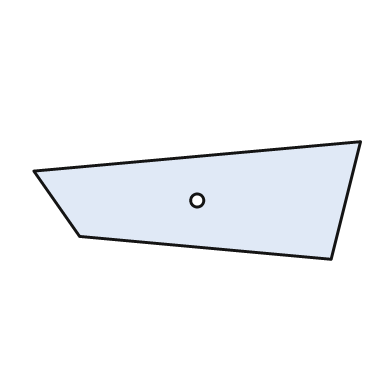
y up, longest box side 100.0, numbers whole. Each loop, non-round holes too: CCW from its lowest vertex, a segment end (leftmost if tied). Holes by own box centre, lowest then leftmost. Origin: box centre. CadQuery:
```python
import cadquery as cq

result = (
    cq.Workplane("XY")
    .moveTo(41.0, -18.0)
    .lineTo(50.0, 18.0)
    .lineTo(-50.0, 9.0)
    .lineTo(-36.0, -11.0)
    .close()
    .moveTo(0.0, 0.0)
    .circle(2.0)
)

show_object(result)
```